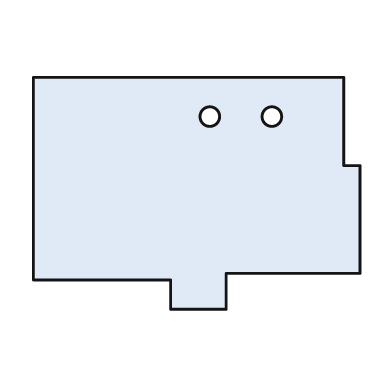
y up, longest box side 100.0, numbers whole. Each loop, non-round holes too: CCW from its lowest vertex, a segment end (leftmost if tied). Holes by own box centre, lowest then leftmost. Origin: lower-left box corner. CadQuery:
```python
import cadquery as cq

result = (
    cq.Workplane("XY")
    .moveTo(42.0, 0.0)
    .lineTo(59.0, 0.0)
    .lineTo(59.0, 11.0)
    .lineTo(100.0, 11.0)
    .lineTo(100.0, 44.0)
    .lineTo(95.0, 44.0)
    .lineTo(95.0, 71.0)
    .lineTo(0.0, 71.0)
    .lineTo(0.0, 9.0)
    .lineTo(42.0, 9.0)
    .close()
    .moveTo(54.0, 59.0)
    .circle(3.0)
    .moveTo(73.0, 59.0)
    .circle(3.0)
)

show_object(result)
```